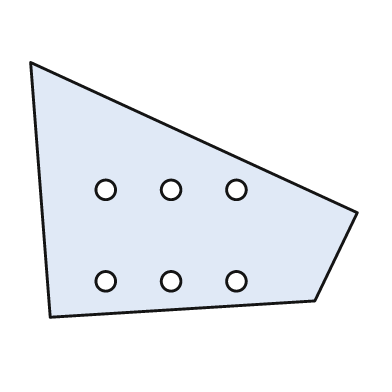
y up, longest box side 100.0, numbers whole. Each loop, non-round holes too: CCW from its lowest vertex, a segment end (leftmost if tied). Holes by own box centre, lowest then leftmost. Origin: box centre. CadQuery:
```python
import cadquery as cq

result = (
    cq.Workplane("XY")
    .moveTo(-44.0, -39.0)
    .lineTo(37.0, -34.0)
    .lineTo(50.0, -7.0)
    .lineTo(-50.0, 39.0)
    .close()
    .moveTo(-27.0, -28.0)
    .circle(3.0)
    .moveTo(-7.0, -28.0)
    .circle(3.0)
    .moveTo(13.0, -28.0)
    .circle(3.0)
    .moveTo(-27.0, 0.0)
    .circle(3.0)
    .moveTo(-7.0, 0.0)
    .circle(3.0)
    .moveTo(13.0, 0.0)
    .circle(3.0)
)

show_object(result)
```